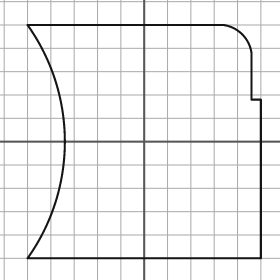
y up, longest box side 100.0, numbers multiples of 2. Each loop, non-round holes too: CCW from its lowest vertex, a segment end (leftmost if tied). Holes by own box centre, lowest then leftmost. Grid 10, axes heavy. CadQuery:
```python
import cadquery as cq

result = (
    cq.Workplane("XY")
    .moveTo(-50.0, -50.0)
    .lineTo(50.0, -50.0)
    .lineTo(50.0, 18.0)
    .lineTo(46.0, 18.0)
    .lineTo(46.0, 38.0)
    .threePointArc((42.0, 46.0), (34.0, 50.0))
    .lineTo(-50.0, 50.0)
    .threePointArc((-34.0, 0.0), (-50.0, -50.0))
    .close()
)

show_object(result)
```